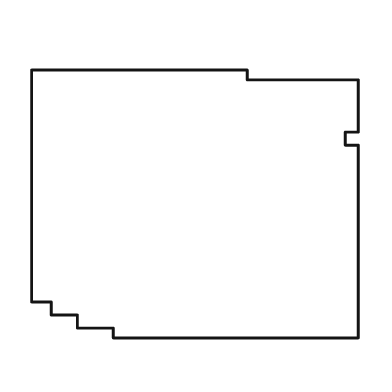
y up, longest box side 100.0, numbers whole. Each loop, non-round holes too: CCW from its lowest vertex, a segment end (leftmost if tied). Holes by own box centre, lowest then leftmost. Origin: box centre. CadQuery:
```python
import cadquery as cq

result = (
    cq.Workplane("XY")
    .moveTo(-25.0, -41.0)
    .lineTo(50.0, -41.0)
    .lineTo(50.0, 18.0)
    .lineTo(46.0, 18.0)
    .lineTo(46.0, 22.0)
    .lineTo(50.0, 22.0)
    .lineTo(50.0, 38.0)
    .lineTo(16.0, 38.0)
    .lineTo(16.0, 41.0)
    .lineTo(-50.0, 41.0)
    .lineTo(-50.0, -30.0)
    .lineTo(-44.0, -30.0)
    .lineTo(-44.0, -34.0)
    .lineTo(-36.0, -34.0)
    .lineTo(-36.0, -38.0)
    .lineTo(-25.0, -38.0)
    .close()
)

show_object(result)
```